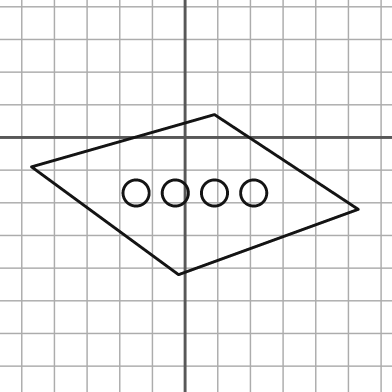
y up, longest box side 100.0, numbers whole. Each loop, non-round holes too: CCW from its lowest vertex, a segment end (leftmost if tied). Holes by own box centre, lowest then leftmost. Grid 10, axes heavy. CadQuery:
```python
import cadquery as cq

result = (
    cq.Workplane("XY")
    .moveTo(-2.0, -42.0)
    .lineTo(53.0, -22.0)
    .lineTo(9.0, 7.0)
    .lineTo(-47.0, -9.0)
    .close()
    .moveTo(-15.0, -17.0)
    .circle(4.0)
    .moveTo(-3.0, -17.0)
    .circle(4.0)
    .moveTo(9.0, -17.0)
    .circle(4.0)
    .moveTo(21.0, -17.0)
    .circle(4.0)
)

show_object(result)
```